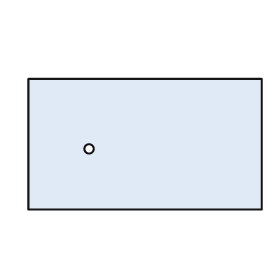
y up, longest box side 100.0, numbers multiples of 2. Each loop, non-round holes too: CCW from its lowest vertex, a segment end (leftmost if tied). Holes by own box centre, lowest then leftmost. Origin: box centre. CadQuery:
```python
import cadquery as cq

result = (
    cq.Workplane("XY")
    .moveTo(-50.0, -28.0)
    .lineTo(50.0, -28.0)
    .lineTo(50.0, 28.0)
    .lineTo(-50.0, 28.0)
    .close()
    .moveTo(-24.0, -2.0)
    .circle(2.0)
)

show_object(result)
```